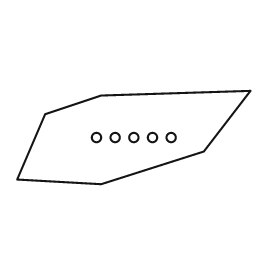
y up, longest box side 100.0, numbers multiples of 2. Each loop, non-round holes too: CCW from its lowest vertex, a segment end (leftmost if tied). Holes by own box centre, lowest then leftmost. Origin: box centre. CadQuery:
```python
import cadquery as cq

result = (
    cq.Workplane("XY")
    .moveTo(-14.0, -20.0)
    .lineTo(30.0, -6.0)
    .lineTo(50.0, 20.0)
    .lineTo(-14.0, 18.0)
    .lineTo(-38.0, 10.0)
    .lineTo(-50.0, -18.0)
    .close()
    .moveTo(-16.0, 0.0)
    .circle(2.0)
    .moveTo(-8.0, 0.0)
    .circle(2.0)
    .moveTo(0.0, 0.0)
    .circle(2.0)
    .moveTo(8.0, 0.0)
    .circle(2.0)
    .moveTo(16.0, 0.0)
    .circle(2.0)
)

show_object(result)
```